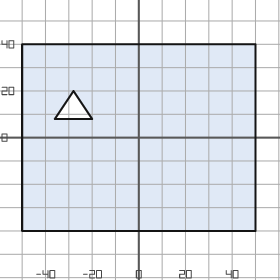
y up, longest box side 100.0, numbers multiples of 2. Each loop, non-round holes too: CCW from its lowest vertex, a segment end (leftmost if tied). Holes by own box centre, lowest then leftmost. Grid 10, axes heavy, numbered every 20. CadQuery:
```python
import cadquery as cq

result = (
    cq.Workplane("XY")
    .moveTo(-50.0, -40.0)
    .lineTo(50.0, -40.0)
    .lineTo(50.0, 40.0)
    .lineTo(-50.0, 40.0)
    .close()
    .moveTo(-36.0, 8.0)
    .lineTo(-20.0, 8.0)
    .lineTo(-28.0, 20.0)
    .close()
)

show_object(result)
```